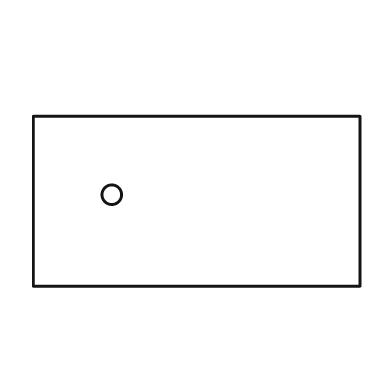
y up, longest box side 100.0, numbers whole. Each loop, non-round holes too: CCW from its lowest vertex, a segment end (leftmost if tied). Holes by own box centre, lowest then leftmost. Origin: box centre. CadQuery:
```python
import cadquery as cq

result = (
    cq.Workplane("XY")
    .moveTo(-50.0, -26.0)
    .lineTo(50.0, -26.0)
    .lineTo(50.0, 26.0)
    .lineTo(-50.0, 26.0)
    .close()
    .moveTo(-26.0, 2.0)
    .circle(3.0)
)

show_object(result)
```